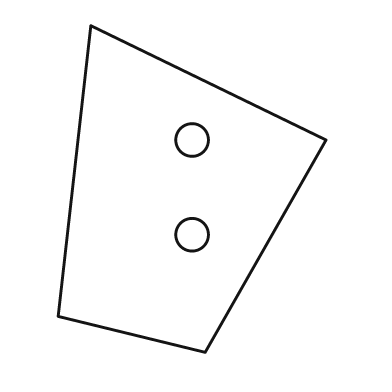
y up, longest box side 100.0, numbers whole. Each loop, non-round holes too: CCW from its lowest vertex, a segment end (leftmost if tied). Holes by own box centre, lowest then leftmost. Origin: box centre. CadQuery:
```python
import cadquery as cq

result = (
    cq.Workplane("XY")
    .moveTo(4.0, -50.0)
    .lineTo(41.0, 15.0)
    .lineTo(-31.0, 50.0)
    .lineTo(-41.0, -39.0)
    .close()
    .moveTo(0.0, -14.0)
    .circle(5.0)
    .moveTo(0.0, 15.0)
    .circle(5.0)
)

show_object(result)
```